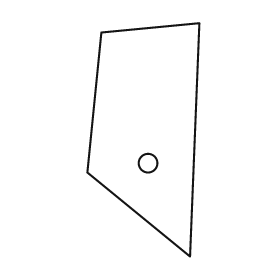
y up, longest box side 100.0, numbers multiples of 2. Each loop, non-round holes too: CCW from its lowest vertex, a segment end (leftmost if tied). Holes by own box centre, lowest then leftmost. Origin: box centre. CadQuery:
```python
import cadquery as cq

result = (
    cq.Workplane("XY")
    .moveTo(20.0, -50.0)
    .lineTo(24.0, 50.0)
    .lineTo(-18.0, 46.0)
    .lineTo(-24.0, -14.0)
    .close()
    .moveTo(2.0, -10.0)
    .circle(4.0)
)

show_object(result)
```